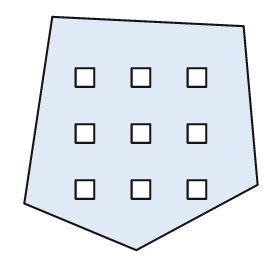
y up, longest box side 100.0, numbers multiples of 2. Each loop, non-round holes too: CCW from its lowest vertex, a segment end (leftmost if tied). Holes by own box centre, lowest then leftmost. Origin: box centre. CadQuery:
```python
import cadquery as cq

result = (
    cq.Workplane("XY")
    .moveTo(-2.0, -50.0)
    .lineTo(50.0, -22.0)
    .lineTo(44.0, 46.0)
    .lineTo(-38.0, 50.0)
    .lineTo(-50.0, -30.0)
    .close()
    .moveTo(-28.0, -28.0)
    .lineTo(-20.0, -28.0)
    .lineTo(-20.0, -20.0)
    .lineTo(-28.0, -20.0)
    .close()
    .moveTo(-4.0, -28.0)
    .lineTo(4.0, -28.0)
    .lineTo(4.0, -20.0)
    .lineTo(-4.0, -20.0)
    .close()
    .moveTo(20.0, -28.0)
    .lineTo(28.0, -28.0)
    .lineTo(28.0, -20.0)
    .lineTo(20.0, -20.0)
    .close()
    .moveTo(-28.0, -4.0)
    .lineTo(-20.0, -4.0)
    .lineTo(-20.0, 4.0)
    .lineTo(-28.0, 4.0)
    .close()
    .moveTo(-4.0, -4.0)
    .lineTo(4.0, -4.0)
    .lineTo(4.0, 4.0)
    .lineTo(-4.0, 4.0)
    .close()
    .moveTo(20.0, -4.0)
    .lineTo(28.0, -4.0)
    .lineTo(28.0, 4.0)
    .lineTo(20.0, 4.0)
    .close()
    .moveTo(-28.0, 20.0)
    .lineTo(-20.0, 20.0)
    .lineTo(-20.0, 28.0)
    .lineTo(-28.0, 28.0)
    .close()
    .moveTo(-4.0, 20.0)
    .lineTo(4.0, 20.0)
    .lineTo(4.0, 28.0)
    .lineTo(-4.0, 28.0)
    .close()
    .moveTo(20.0, 20.0)
    .lineTo(28.0, 20.0)
    .lineTo(28.0, 28.0)
    .lineTo(20.0, 28.0)
    .close()
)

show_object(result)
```